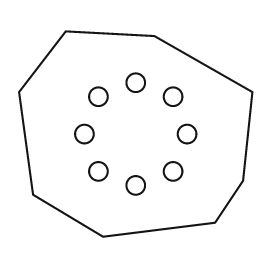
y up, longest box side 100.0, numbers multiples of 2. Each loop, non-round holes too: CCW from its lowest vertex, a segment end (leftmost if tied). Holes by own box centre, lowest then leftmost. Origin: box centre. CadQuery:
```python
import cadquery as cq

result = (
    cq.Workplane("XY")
    .moveTo(-14.0, -44.0)
    .lineTo(34.0, -38.0)
    .lineTo(46.0, -20.0)
    .lineTo(50.0, 18.0)
    .lineTo(8.0, 42.0)
    .lineTo(-30.0, 44.0)
    .lineTo(-50.0, 18.0)
    .lineTo(-44.0, -26.0)
    .close()
    .moveTo(0.0, -22.0)
    .circle(4.0)
    .moveTo(-16.0, -16.0)
    .circle(4.0)
    .moveTo(16.0, -16.0)
    .circle(4.0)
    .moveTo(-22.0, 0.0)
    .circle(4.0)
    .moveTo(22.0, 0.0)
    .circle(4.0)
    .moveTo(-16.0, 16.0)
    .circle(4.0)
    .moveTo(16.0, 16.0)
    .circle(4.0)
    .moveTo(0.0, 22.0)
    .circle(4.0)
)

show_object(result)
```